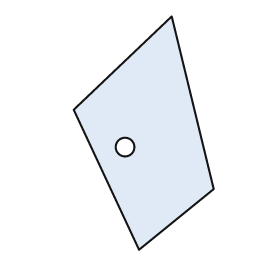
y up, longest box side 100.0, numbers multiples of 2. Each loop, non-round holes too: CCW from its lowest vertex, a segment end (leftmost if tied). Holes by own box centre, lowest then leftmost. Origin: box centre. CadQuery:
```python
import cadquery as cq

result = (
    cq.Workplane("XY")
    .moveTo(-2.0, -50.0)
    .lineTo(30.0, -24.0)
    .lineTo(12.0, 50.0)
    .lineTo(-30.0, 10.0)
    .close()
    .moveTo(-8.0, -6.0)
    .circle(4.0)
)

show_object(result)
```